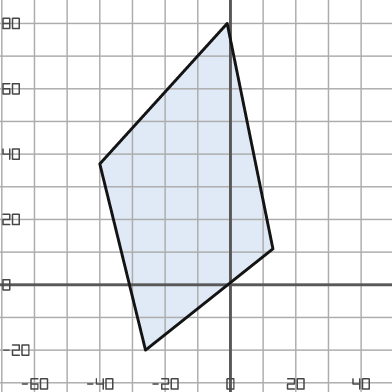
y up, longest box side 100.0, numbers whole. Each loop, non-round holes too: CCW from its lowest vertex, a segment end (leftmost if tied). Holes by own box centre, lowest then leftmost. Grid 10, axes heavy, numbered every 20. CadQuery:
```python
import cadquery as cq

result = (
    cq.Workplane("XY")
    .moveTo(-26.0, -20.0)
    .lineTo(13.0, 11.0)
    .lineTo(-1.0, 80.0)
    .lineTo(-40.0, 37.0)
    .close()
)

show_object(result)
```